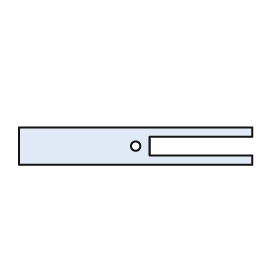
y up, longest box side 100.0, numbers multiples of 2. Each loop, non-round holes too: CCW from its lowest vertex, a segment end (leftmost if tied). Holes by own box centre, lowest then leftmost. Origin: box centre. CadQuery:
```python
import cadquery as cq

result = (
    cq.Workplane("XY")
    .moveTo(-50.0, -8.0)
    .lineTo(50.0, -8.0)
    .lineTo(50.0, -4.0)
    .lineTo(6.0, -4.0)
    .lineTo(6.0, 4.0)
    .lineTo(50.0, 4.0)
    .lineTo(50.0, 8.0)
    .lineTo(-50.0, 8.0)
    .close()
    .moveTo(0.0, 0.0)
    .circle(2.0)
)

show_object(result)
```